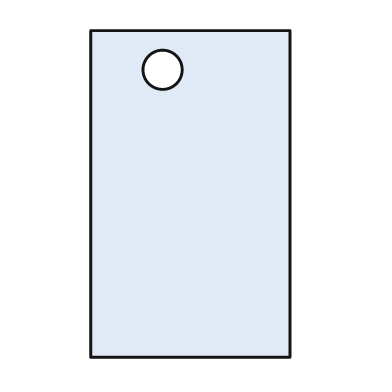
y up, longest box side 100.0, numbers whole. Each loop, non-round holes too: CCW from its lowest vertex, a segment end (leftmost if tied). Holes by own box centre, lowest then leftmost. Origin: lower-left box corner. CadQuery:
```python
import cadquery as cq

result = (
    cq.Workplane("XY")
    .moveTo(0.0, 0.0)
    .lineTo(61.0, 0.0)
    .lineTo(61.0, 100.0)
    .lineTo(0.0, 100.0)
    .close()
    .moveTo(22.0, 88.0)
    .circle(6.0)
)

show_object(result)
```